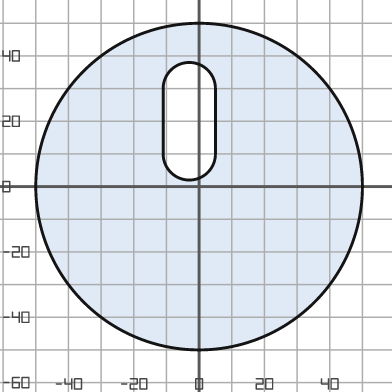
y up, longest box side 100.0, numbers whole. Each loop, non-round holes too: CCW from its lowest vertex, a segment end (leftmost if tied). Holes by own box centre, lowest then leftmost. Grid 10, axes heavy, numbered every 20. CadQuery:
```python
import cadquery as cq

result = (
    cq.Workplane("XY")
    .moveTo(0.0, 0.0)
    .circle(50.0)
    .moveTo(-11.0, 10.0)
    .threePointArc((-3.0, 2.0), (5.0, 10.0))
    .lineTo(5.0, 30.0)
    .threePointArc((-3.0, 38.0), (-11.0, 30.0))
    .close()
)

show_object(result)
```